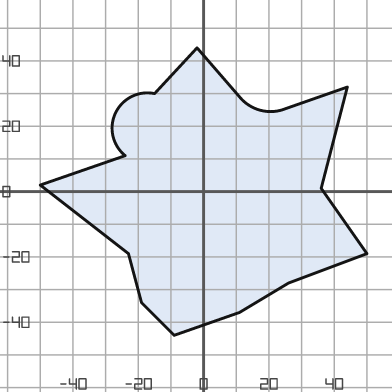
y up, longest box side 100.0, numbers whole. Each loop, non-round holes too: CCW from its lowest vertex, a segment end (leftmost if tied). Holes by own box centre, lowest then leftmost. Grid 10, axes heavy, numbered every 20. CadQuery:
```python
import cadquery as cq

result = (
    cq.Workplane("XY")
    .moveTo(-9.0, -44.0)
    .lineTo(11.0, -37.0)
    .lineTo(26.0, -28.0)
    .lineTo(50.0, -19.0)
    .lineTo(36.0, 1.0)
    .lineTo(44.0, 32.0)
    .lineTo(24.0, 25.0)
    .threePointArc((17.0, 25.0), (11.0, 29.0))
    .lineTo(-2.0, 44.0)
    .lineTo(-15.0, 30.0)
    .threePointArc((-27.0, 24.0), (-24.0, 11.0))
    .lineTo(-50.0, 2.0)
    .lineTo(-23.0, -19.0)
    .lineTo(-19.0, -34.0)
    .close()
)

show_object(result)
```